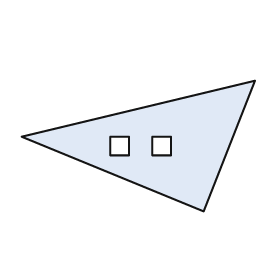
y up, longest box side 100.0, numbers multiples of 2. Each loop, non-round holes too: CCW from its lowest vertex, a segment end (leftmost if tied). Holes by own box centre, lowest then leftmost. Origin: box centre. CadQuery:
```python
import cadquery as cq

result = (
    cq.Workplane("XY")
    .moveTo(28.0, -28.0)
    .lineTo(50.0, 28.0)
    .lineTo(-50.0, 4.0)
    .close()
    .moveTo(-12.0, -4.0)
    .lineTo(-4.0, -4.0)
    .lineTo(-4.0, 4.0)
    .lineTo(-12.0, 4.0)
    .close()
    .moveTo(6.0, -4.0)
    .lineTo(14.0, -4.0)
    .lineTo(14.0, 4.0)
    .lineTo(6.0, 4.0)
    .close()
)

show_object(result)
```